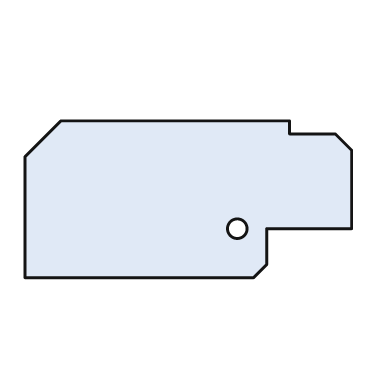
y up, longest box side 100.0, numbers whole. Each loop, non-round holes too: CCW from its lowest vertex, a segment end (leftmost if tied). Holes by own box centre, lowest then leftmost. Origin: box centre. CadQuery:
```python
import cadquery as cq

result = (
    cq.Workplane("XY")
    .moveTo(-50.0, -24.0)
    .lineTo(20.0, -24.0)
    .lineTo(24.0, -20.0)
    .lineTo(24.0, -9.0)
    .lineTo(50.0, -9.0)
    .lineTo(50.0, 15.0)
    .lineTo(45.0, 20.0)
    .lineTo(31.0, 20.0)
    .lineTo(31.0, 24.0)
    .lineTo(-39.0, 24.0)
    .lineTo(-50.0, 13.0)
    .close()
    .moveTo(15.0, -9.0)
    .circle(3.0)
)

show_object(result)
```